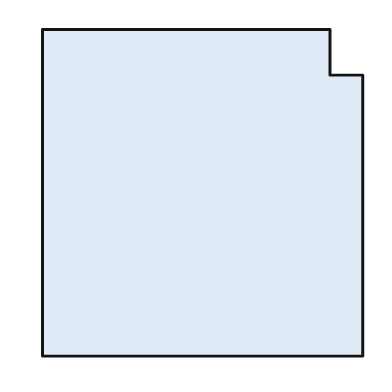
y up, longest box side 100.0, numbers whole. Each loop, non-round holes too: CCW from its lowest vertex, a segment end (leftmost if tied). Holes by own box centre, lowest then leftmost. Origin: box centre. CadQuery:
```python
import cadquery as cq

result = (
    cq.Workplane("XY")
    .moveTo(-49.0, -50.0)
    .lineTo(49.0, -50.0)
    .lineTo(49.0, 36.0)
    .lineTo(39.0, 36.0)
    .lineTo(39.0, 50.0)
    .lineTo(-49.0, 50.0)
    .close()
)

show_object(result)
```